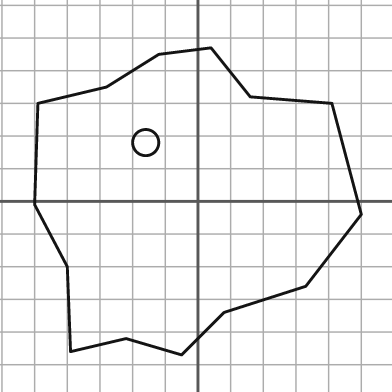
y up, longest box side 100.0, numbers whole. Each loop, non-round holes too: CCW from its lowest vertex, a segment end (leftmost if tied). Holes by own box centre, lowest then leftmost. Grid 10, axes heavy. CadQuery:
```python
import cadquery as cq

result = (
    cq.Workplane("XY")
    .moveTo(-5.0, -47.0)
    .lineTo(8.0, -34.0)
    .lineTo(33.0, -26.0)
    .lineTo(50.0, -4.0)
    .lineTo(41.0, 30.0)
    .lineTo(16.0, 32.0)
    .lineTo(4.0, 47.0)
    .lineTo(-12.0, 45.0)
    .lineTo(-28.0, 35.0)
    .lineTo(-49.0, 30.0)
    .lineTo(-50.0, -1.0)
    .lineTo(-40.0, -20.0)
    .lineTo(-39.0, -46.0)
    .lineTo(-22.0, -42.0)
    .close()
    .moveTo(-16.0, 18.0)
    .circle(4.0)
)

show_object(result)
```